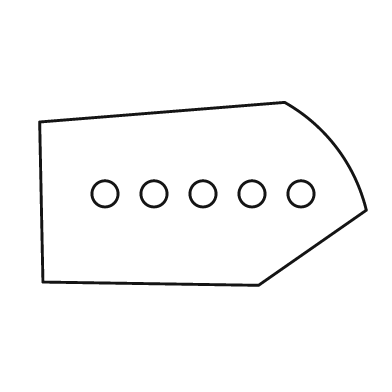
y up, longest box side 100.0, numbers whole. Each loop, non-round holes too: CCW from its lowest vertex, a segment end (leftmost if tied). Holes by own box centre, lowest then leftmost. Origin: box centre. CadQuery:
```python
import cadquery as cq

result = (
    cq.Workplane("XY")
    .moveTo(17.0, -28.0)
    .lineTo(50.0, -5.0)
    .threePointArc((41.0, 14.0), (25.0, 28.0))
    .lineTo(-50.0, 22.0)
    .lineTo(-49.0, -27.0)
    .close()
    .moveTo(-30.0, 0.0)
    .circle(4.0)
    .moveTo(-15.0, 0.0)
    .circle(4.0)
    .moveTo(0.0, 0.0)
    .circle(4.0)
    .moveTo(15.0, 0.0)
    .circle(4.0)
    .moveTo(30.0, 0.0)
    .circle(4.0)
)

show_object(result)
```